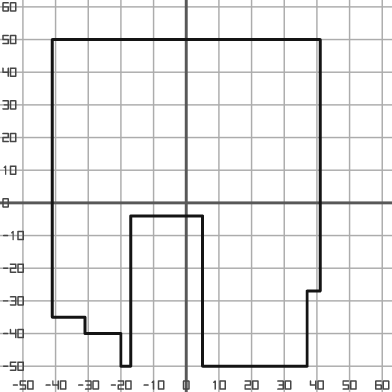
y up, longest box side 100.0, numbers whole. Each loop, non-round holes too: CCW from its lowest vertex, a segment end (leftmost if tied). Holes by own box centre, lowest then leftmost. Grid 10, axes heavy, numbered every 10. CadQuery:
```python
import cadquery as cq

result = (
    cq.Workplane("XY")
    .moveTo(-20.0, -50.0)
    .lineTo(-17.0, -50.0)
    .lineTo(-17.0, -4.0)
    .lineTo(5.0, -4.0)
    .lineTo(5.0, -50.0)
    .lineTo(37.0, -50.0)
    .lineTo(37.0, -27.0)
    .lineTo(41.0, -27.0)
    .lineTo(41.0, 50.0)
    .lineTo(-41.0, 50.0)
    .lineTo(-41.0, -35.0)
    .lineTo(-31.0, -35.0)
    .lineTo(-31.0, -40.0)
    .lineTo(-20.0, -40.0)
    .close()
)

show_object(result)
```